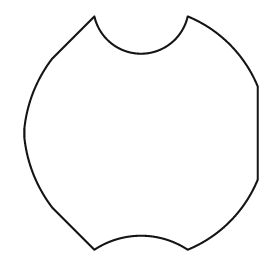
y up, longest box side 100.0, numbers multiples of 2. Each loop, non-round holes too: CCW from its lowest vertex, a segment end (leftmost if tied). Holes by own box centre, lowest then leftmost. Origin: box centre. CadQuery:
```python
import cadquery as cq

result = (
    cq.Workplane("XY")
    .moveTo(-20.0, -50.0)
    .threePointArc((0.0, -44.0), (20.0, -50.0))
    .threePointArc((38.0, -38.0), (50.0, -20.0))
    .lineTo(50.0, 20.0)
    .threePointArc((38.0, 38.0), (20.0, 50.0))
    .threePointArc((0.0, 34.0), (-20.0, 50.0))
    .lineTo(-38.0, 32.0)
    .threePointArc((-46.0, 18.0), (-50.0, 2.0))
    .lineTo(-50.0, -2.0)
    .threePointArc((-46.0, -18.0), (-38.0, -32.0))
    .close()
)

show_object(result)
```